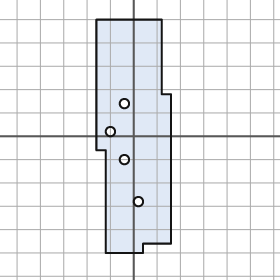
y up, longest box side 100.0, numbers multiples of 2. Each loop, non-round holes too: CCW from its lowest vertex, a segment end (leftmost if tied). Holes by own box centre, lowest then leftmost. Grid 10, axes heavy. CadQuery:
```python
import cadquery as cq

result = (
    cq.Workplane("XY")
    .moveTo(-12.0, -50.0)
    .lineTo(4.0, -50.0)
    .lineTo(4.0, -46.0)
    .lineTo(16.0, -46.0)
    .lineTo(16.0, 18.0)
    .lineTo(12.0, 18.0)
    .lineTo(12.0, 50.0)
    .lineTo(-16.0, 50.0)
    .lineTo(-16.0, -6.0)
    .lineTo(-12.0, -6.0)
    .close()
    .moveTo(2.0, -28.0)
    .circle(2.0)
    .moveTo(-4.0, -10.0)
    .circle(2.0)
    .moveTo(-10.0, 2.0)
    .circle(2.0)
    .moveTo(-4.0, 14.0)
    .circle(2.0)
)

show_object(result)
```